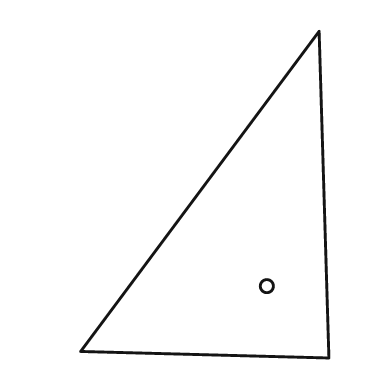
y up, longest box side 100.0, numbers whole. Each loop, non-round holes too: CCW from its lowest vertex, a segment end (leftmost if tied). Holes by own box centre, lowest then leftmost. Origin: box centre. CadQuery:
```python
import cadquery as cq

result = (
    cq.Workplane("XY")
    .moveTo(38.0, -50.0)
    .lineTo(35.0, 50.0)
    .lineTo(-38.0, -48.0)
    .close()
    .moveTo(19.0, -28.0)
    .circle(2.0)
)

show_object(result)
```